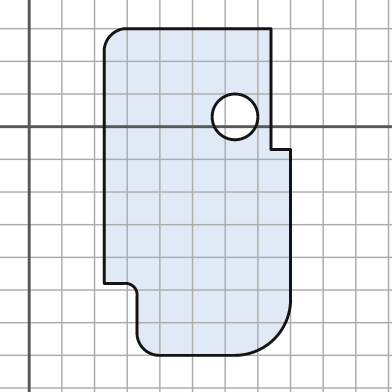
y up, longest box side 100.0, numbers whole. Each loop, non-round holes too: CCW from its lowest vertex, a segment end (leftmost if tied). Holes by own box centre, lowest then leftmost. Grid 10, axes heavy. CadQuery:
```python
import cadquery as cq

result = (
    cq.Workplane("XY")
    .moveTo(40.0, -70.0)
    .lineTo(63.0, -70.0)
    .threePointArc((75.0, -65.0), (80.0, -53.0))
    .lineTo(80.0, -7.0)
    .lineTo(74.0, -7.0)
    .lineTo(74.0, 30.0)
    .lineTo(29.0, 30.0)
    .threePointArc((25.0, 28.0), (23.0, 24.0))
    .lineTo(23.0, -48.0)
    .lineTo(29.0, -48.0)
    .threePointArc((32.0, -49.0), (33.0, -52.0))
    .lineTo(33.0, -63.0)
    .threePointArc((35.0, -68.0), (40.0, -70.0))
    .close()
    .moveTo(63.0, 3.0)
    .circle(7.0)
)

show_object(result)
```